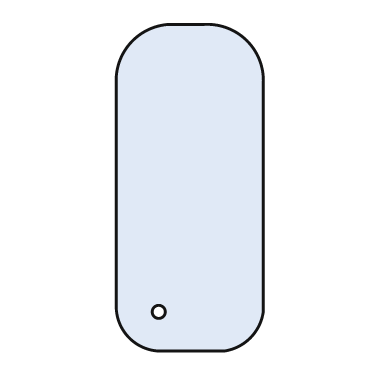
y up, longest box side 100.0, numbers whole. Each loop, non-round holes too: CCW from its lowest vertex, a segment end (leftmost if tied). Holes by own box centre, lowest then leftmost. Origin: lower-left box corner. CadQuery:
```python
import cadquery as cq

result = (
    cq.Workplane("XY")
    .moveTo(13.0, 0.0)
    .lineTo(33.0, 0.0)
    .threePointArc((41.0, 4.0), (45.0, 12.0))
    .lineTo(45.0, 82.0)
    .threePointArc((40.0, 95.0), (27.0, 100.0))
    .lineTo(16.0, 100.0)
    .threePointArc((5.0, 95.0), (0.0, 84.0))
    .lineTo(0.0, 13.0)
    .threePointArc((4.0, 4.0), (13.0, 0.0))
    .close()
    .moveTo(13.0, 12.0)
    .circle(2.0)
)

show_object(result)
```